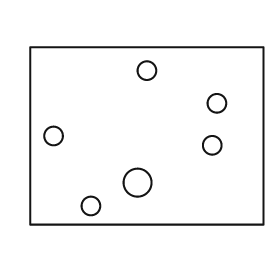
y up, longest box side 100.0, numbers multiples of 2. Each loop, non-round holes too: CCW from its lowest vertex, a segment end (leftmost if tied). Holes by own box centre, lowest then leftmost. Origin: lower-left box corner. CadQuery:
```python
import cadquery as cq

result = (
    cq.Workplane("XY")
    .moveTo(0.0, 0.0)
    .lineTo(100.0, 0.0)
    .lineTo(100.0, 76.0)
    .lineTo(0.0, 76.0)
    .close()
    .moveTo(26.0, 8.0)
    .circle(4.0)
    .moveTo(46.0, 18.0)
    .circle(6.0)
    .moveTo(78.0, 34.0)
    .circle(4.0)
    .moveTo(10.0, 38.0)
    .circle(4.0)
    .moveTo(80.0, 52.0)
    .circle(4.0)
    .moveTo(50.0, 66.0)
    .circle(4.0)
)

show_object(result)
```